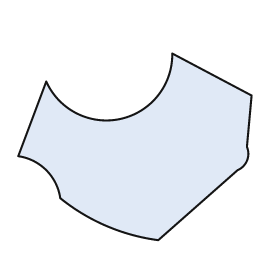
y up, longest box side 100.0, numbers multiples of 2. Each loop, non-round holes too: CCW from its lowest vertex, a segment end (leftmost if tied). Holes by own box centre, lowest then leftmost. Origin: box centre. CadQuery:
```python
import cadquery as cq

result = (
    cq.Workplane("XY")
    .moveTo(10.0, -40.0)
    .lineTo(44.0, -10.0)
    .threePointArc((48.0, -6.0), (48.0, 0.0))
    .lineTo(50.0, 22.0)
    .lineTo(16.0, 40.0)
    .threePointArc((-6.0, 12.0), (-38.0, 28.0))
    .lineTo(-50.0, -4.0)
    .threePointArc((-38.0, -10.0), (-32.0, -22.0))
    .threePointArc((-12.0, -34.0), (10.0, -40.0))
    .close()
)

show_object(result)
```